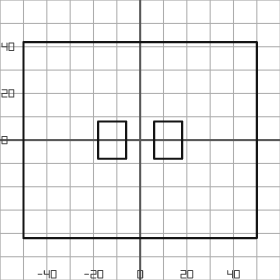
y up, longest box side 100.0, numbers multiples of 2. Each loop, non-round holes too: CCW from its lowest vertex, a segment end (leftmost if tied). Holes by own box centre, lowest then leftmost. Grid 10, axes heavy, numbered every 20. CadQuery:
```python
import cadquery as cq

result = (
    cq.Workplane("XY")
    .moveTo(-50.0, -42.0)
    .lineTo(50.0, -42.0)
    .lineTo(50.0, 42.0)
    .lineTo(-50.0, 42.0)
    .close()
    .moveTo(-18.0, -8.0)
    .lineTo(-6.0, -8.0)
    .lineTo(-6.0, 8.0)
    .lineTo(-18.0, 8.0)
    .close()
    .moveTo(6.0, -8.0)
    .lineTo(18.0, -8.0)
    .lineTo(18.0, 8.0)
    .lineTo(6.0, 8.0)
    .close()
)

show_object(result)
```